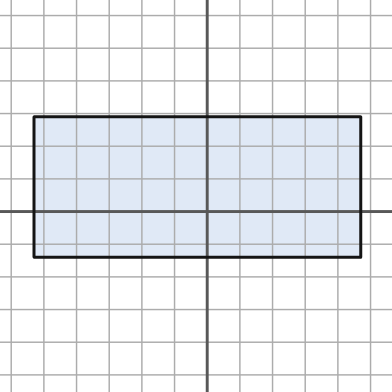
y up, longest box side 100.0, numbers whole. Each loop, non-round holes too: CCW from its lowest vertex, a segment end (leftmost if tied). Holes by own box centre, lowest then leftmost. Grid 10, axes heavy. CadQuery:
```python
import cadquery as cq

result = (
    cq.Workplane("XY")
    .moveTo(-53.0, -14.0)
    .lineTo(47.0, -14.0)
    .lineTo(47.0, 29.0)
    .lineTo(-53.0, 29.0)
    .close()
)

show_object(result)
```